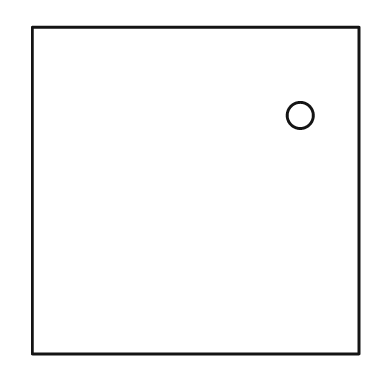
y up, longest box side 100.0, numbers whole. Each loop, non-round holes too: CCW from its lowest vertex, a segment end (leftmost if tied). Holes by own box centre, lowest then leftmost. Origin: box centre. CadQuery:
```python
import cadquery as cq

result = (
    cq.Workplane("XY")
    .moveTo(-50.0, -50.0)
    .lineTo(50.0, -50.0)
    .lineTo(50.0, 50.0)
    .lineTo(-50.0, 50.0)
    .close()
    .moveTo(32.0, 23.0)
    .circle(4.0)
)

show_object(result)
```